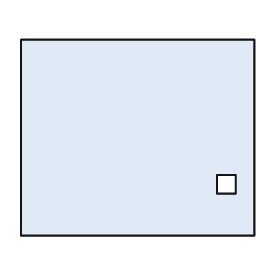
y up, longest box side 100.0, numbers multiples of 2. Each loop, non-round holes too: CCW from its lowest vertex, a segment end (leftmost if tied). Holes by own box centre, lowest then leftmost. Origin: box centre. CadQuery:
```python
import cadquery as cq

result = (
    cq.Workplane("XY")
    .moveTo(-50.0, -42.0)
    .lineTo(50.0, -42.0)
    .lineTo(50.0, 42.0)
    .lineTo(-50.0, 42.0)
    .close()
    .moveTo(34.0, -24.0)
    .lineTo(42.0, -24.0)
    .lineTo(42.0, -16.0)
    .lineTo(34.0, -16.0)
    .close()
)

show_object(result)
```